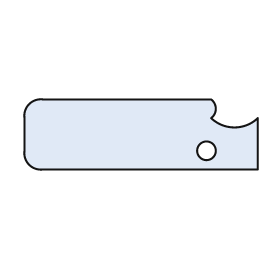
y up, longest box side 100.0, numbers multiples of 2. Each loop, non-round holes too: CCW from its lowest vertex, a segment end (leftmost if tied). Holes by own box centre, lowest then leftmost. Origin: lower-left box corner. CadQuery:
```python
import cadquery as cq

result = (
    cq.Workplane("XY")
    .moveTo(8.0, 0.0)
    .lineTo(100.0, 0.0)
    .lineTo(100.0, 22.0)
    .threePointArc((90.0, 18.0), (80.0, 22.0))
    .threePointArc((82.0, 26.0), (80.0, 30.0))
    .lineTo(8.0, 30.0)
    .threePointArc((2.0, 28.0), (0.0, 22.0))
    .lineTo(0.0, 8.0)
    .threePointArc((2.0, 2.0), (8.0, 0.0))
    .close()
    .moveTo(78.0, 8.0)
    .circle(4.0)
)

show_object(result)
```